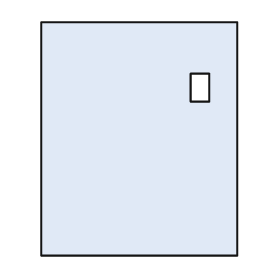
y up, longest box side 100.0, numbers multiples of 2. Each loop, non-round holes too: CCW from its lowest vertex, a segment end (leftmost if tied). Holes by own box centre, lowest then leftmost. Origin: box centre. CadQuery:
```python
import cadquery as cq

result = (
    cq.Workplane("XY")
    .moveTo(-42.0, -50.0)
    .lineTo(42.0, -50.0)
    .lineTo(42.0, 50.0)
    .lineTo(-42.0, 50.0)
    .close()
    .moveTo(22.0, 16.0)
    .lineTo(30.0, 16.0)
    .lineTo(30.0, 28.0)
    .lineTo(22.0, 28.0)
    .close()
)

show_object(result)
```